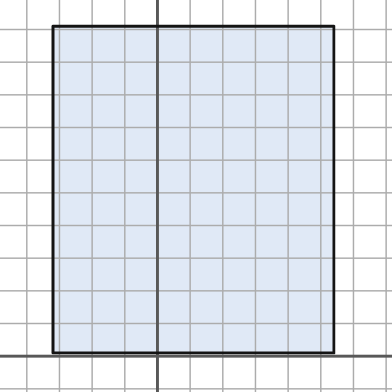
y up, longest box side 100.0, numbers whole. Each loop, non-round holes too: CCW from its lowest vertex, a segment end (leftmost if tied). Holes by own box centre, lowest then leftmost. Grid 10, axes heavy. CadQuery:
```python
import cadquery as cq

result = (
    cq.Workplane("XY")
    .moveTo(-32.0, 1.0)
    .lineTo(54.0, 1.0)
    .lineTo(54.0, 101.0)
    .lineTo(-32.0, 101.0)
    .close()
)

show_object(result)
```